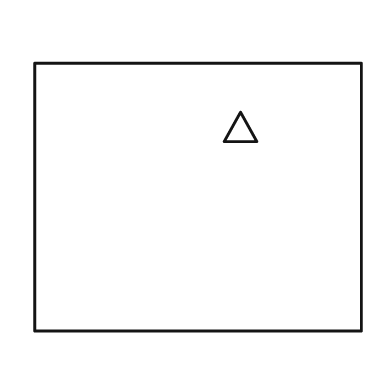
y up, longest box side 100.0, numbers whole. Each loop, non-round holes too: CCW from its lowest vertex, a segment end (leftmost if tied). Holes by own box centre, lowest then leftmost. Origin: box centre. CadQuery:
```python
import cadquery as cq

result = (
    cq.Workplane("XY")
    .moveTo(-50.0, -41.0)
    .lineTo(50.0, -41.0)
    .lineTo(50.0, 41.0)
    .lineTo(-50.0, 41.0)
    .close()
    .moveTo(8.0, 17.0)
    .lineTo(18.0, 17.0)
    .lineTo(13.0, 26.0)
    .close()
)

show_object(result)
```